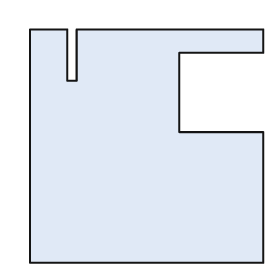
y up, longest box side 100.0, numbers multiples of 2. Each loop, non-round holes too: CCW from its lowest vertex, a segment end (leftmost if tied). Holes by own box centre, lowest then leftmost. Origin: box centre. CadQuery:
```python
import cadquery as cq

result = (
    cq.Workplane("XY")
    .moveTo(-50.0, -50.0)
    .lineTo(50.0, -50.0)
    .lineTo(50.0, 6.0)
    .lineTo(14.0, 6.0)
    .lineTo(14.0, 40.0)
    .lineTo(50.0, 40.0)
    .lineTo(50.0, 50.0)
    .lineTo(-30.0, 50.0)
    .lineTo(-30.0, 28.0)
    .lineTo(-34.0, 28.0)
    .lineTo(-34.0, 50.0)
    .lineTo(-50.0, 50.0)
    .close()
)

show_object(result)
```